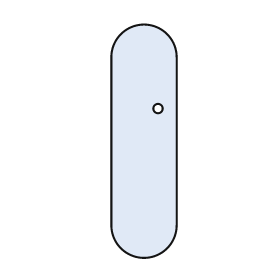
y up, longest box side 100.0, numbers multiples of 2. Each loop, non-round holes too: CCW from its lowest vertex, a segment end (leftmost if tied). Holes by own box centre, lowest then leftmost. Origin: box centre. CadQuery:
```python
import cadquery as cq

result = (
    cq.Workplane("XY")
    .moveTo(-14.0, -36.0)
    .threePointArc((0.0, -50.0), (14.0, -36.0))
    .lineTo(14.0, 36.0)
    .threePointArc((0.0, 50.0), (-14.0, 36.0))
    .close()
    .moveTo(6.0, 14.0)
    .circle(2.0)
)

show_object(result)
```